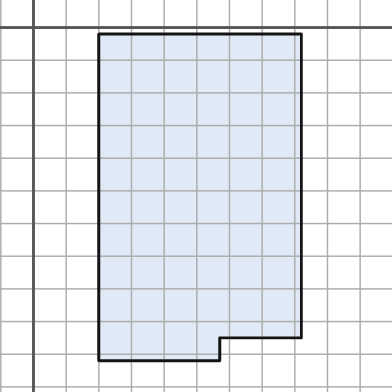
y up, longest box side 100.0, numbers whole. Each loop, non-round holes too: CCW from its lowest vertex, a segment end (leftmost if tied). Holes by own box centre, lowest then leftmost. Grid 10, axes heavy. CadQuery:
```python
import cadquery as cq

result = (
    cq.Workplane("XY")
    .moveTo(20.0, -102.0)
    .lineTo(57.0, -102.0)
    .lineTo(57.0, -95.0)
    .lineTo(82.0, -95.0)
    .lineTo(82.0, -2.0)
    .lineTo(20.0, -2.0)
    .close()
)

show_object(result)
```